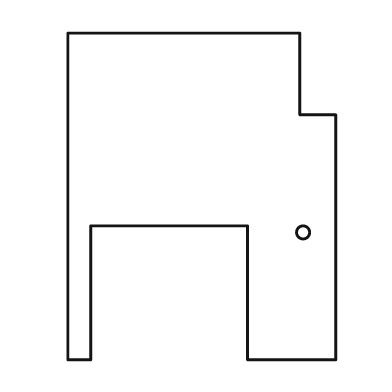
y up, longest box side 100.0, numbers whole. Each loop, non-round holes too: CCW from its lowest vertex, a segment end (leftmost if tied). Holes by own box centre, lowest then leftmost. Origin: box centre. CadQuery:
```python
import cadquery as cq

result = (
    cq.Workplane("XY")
    .moveTo(-41.0, -50.0)
    .lineTo(-34.0, -50.0)
    .lineTo(-34.0, -9.0)
    .lineTo(14.0, -9.0)
    .lineTo(14.0, -50.0)
    .lineTo(41.0, -50.0)
    .lineTo(41.0, 25.0)
    .lineTo(30.0, 25.0)
    .lineTo(30.0, 50.0)
    .lineTo(-41.0, 50.0)
    .close()
    .moveTo(31.0, -11.0)
    .circle(2.0)
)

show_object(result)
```